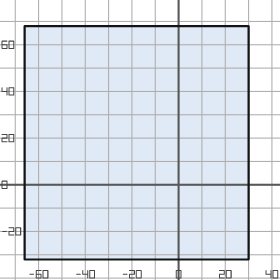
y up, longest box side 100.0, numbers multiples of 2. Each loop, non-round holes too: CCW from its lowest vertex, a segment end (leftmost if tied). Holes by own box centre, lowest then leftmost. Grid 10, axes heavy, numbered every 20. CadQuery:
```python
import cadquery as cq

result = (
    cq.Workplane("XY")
    .moveTo(-66.0, -32.0)
    .lineTo(30.0, -32.0)
    .lineTo(30.0, 68.0)
    .lineTo(-66.0, 68.0)
    .close()
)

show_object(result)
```